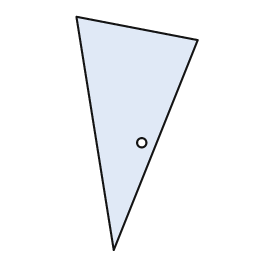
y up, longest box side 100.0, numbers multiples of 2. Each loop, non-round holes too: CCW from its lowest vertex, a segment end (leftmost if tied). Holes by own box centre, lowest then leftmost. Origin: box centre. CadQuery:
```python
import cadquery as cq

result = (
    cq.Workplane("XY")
    .moveTo(-10.0, -50.0)
    .lineTo(26.0, 40.0)
    .lineTo(-26.0, 50.0)
    .close()
    .moveTo(2.0, -4.0)
    .circle(2.0)
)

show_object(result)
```